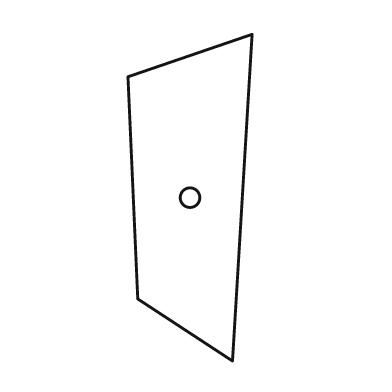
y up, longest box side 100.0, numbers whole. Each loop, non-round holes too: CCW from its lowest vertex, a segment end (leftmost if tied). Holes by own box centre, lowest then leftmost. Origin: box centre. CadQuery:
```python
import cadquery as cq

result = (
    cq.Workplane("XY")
    .moveTo(13.0, -50.0)
    .lineTo(19.0, 50.0)
    .lineTo(-19.0, 37.0)
    .lineTo(-16.0, -31.0)
    .close()
    .moveTo(0.0, 0.0)
    .circle(3.0)
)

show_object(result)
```